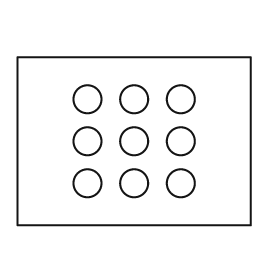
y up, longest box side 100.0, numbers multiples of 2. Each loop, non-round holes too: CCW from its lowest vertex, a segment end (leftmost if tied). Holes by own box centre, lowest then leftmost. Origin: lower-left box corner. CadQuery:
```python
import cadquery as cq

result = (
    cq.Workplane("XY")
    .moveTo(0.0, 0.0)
    .lineTo(100.0, 0.0)
    .lineTo(100.0, 72.0)
    .lineTo(0.0, 72.0)
    .close()
    .moveTo(30.0, 18.0)
    .circle(6.0)
    .moveTo(50.0, 18.0)
    .circle(6.0)
    .moveTo(70.0, 18.0)
    .circle(6.0)
    .moveTo(30.0, 36.0)
    .circle(6.0)
    .moveTo(50.0, 36.0)
    .circle(6.0)
    .moveTo(70.0, 36.0)
    .circle(6.0)
    .moveTo(30.0, 54.0)
    .circle(6.0)
    .moveTo(50.0, 54.0)
    .circle(6.0)
    .moveTo(70.0, 54.0)
    .circle(6.0)
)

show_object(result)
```